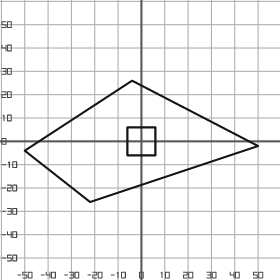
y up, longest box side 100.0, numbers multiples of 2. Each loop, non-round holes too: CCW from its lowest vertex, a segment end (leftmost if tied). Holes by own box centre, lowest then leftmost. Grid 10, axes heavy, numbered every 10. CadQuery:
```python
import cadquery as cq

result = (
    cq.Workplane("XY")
    .moveTo(-22.0, -26.0)
    .lineTo(50.0, -2.0)
    .lineTo(-4.0, 26.0)
    .lineTo(-50.0, -4.0)
    .close()
    .moveTo(-6.0, -6.0)
    .lineTo(6.0, -6.0)
    .lineTo(6.0, 6.0)
    .lineTo(-6.0, 6.0)
    .close()
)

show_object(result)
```